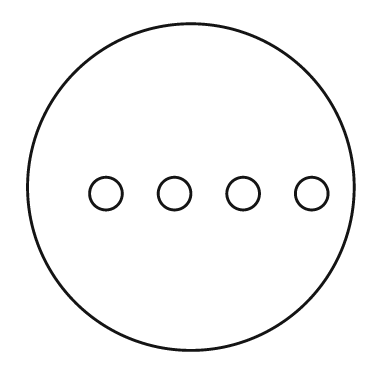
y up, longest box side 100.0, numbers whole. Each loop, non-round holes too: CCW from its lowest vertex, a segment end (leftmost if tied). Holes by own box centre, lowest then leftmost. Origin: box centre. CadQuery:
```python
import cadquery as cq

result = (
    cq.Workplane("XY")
    .moveTo(0.0, 0.0)
    .circle(50.0)
    .moveTo(-26.0, -2.0)
    .circle(5.0)
    .moveTo(-5.0, -2.0)
    .circle(5.0)
    .moveTo(16.0, -2.0)
    .circle(5.0)
    .moveTo(37.0, -2.0)
    .circle(5.0)
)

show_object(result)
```